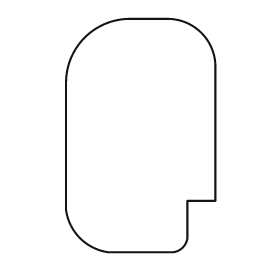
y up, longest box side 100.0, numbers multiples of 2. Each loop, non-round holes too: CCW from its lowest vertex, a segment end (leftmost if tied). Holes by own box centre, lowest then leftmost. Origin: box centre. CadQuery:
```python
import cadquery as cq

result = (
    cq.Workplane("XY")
    .moveTo(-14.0, -50.0)
    .lineTo(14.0, -50.0)
    .threePointArc((18.0, -48.0), (20.0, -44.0))
    .lineTo(20.0, -28.0)
    .lineTo(32.0, -28.0)
    .lineTo(32.0, 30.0)
    .threePointArc((26.0, 44.0), (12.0, 50.0))
    .lineTo(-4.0, 50.0)
    .threePointArc((-24.0, 42.0), (-32.0, 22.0))
    .lineTo(-32.0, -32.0)
    .threePointArc((-26.0, -44.0), (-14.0, -50.0))
    .close()
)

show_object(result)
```